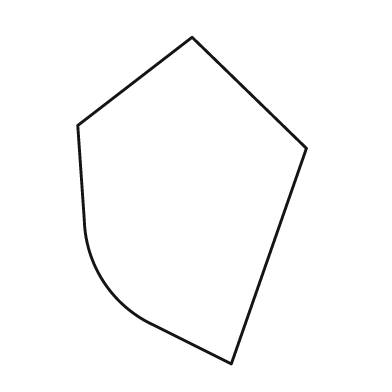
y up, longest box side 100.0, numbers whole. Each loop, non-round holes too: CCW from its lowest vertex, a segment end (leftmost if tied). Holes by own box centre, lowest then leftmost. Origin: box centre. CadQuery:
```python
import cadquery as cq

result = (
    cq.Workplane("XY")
    .moveTo(12.0, -50.0)
    .lineTo(35.0, 16.0)
    .lineTo(0.0, 50.0)
    .lineTo(-35.0, 23.0)
    .lineTo(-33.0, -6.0)
    .threePointArc((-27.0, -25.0), (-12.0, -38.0))
    .close()
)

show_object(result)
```